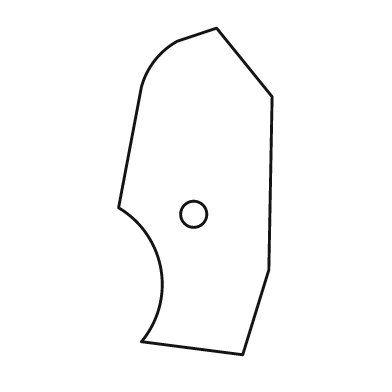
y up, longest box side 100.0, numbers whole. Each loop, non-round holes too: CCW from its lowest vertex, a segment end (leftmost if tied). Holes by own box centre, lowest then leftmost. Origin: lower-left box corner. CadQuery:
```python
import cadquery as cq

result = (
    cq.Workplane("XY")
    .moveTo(38.0, 0.0)
    .lineTo(46.0, 26.0)
    .lineTo(47.0, 79.0)
    .lineTo(30.0, 100.0)
    .lineTo(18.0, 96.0)
    .threePointArc((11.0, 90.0), (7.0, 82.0))
    .lineTo(0.0, 45.0)
    .threePointArc((13.0, 26.0), (7.0, 4.0))
    .close()
    .moveTo(23.0, 43.0)
    .circle(4.0)
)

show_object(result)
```